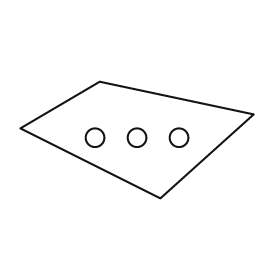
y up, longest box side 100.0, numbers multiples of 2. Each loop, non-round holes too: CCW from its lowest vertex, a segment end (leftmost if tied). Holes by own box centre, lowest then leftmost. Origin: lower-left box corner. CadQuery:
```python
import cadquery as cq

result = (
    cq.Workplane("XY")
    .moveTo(60.0, 0.0)
    .lineTo(100.0, 36.0)
    .lineTo(34.0, 50.0)
    .lineTo(0.0, 30.0)
    .close()
    .moveTo(32.0, 26.0)
    .circle(4.0)
    .moveTo(50.0, 26.0)
    .circle(4.0)
    .moveTo(68.0, 26.0)
    .circle(4.0)
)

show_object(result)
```